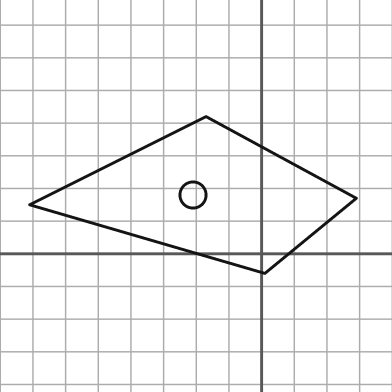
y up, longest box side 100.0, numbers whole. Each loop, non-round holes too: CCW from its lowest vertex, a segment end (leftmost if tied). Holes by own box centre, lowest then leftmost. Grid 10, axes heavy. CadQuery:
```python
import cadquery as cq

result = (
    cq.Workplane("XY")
    .moveTo(1.0, -6.0)
    .lineTo(29.0, 17.0)
    .lineTo(-17.0, 42.0)
    .lineTo(-71.0, 15.0)
    .close()
    .moveTo(-21.0, 18.0)
    .circle(4.0)
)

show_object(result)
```